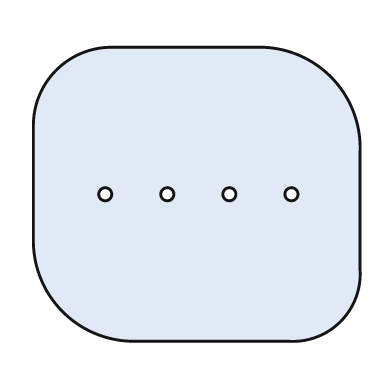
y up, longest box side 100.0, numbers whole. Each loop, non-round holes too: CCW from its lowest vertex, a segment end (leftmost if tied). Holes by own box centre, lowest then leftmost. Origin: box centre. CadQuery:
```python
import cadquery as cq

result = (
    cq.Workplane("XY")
    .moveTo(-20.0, -45.0)
    .lineTo(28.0, -45.0)
    .threePointArc((44.0, -39.0), (50.0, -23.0))
    .lineTo(50.0, 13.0)
    .threePointArc((41.0, 36.0), (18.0, 45.0))
    .lineTo(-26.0, 45.0)
    .threePointArc((-43.0, 38.0), (-50.0, 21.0))
    .lineTo(-50.0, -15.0)
    .threePointArc((-41.0, -36.0), (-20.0, -45.0))
    .close()
    .moveTo(-28.0, 0.0)
    .circle(2.0)
    .moveTo(-9.0, 0.0)
    .circle(2.0)
    .moveTo(10.0, 0.0)
    .circle(2.0)
    .moveTo(29.0, 0.0)
    .circle(2.0)
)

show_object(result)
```